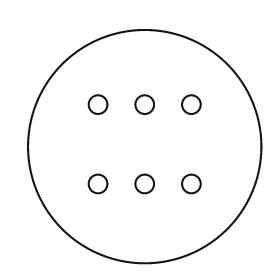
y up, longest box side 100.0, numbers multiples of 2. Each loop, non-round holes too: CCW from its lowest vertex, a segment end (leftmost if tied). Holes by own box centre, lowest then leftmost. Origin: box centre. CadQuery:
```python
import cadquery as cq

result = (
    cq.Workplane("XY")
    .moveTo(0.0, 0.0)
    .circle(50.0)
    .moveTo(-20.0, -16.0)
    .circle(4.0)
    .moveTo(0.0, -16.0)
    .circle(4.0)
    .moveTo(20.0, -16.0)
    .circle(4.0)
    .moveTo(-20.0, 18.0)
    .circle(4.0)
    .moveTo(0.0, 18.0)
    .circle(4.0)
    .moveTo(20.0, 18.0)
    .circle(4.0)
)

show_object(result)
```